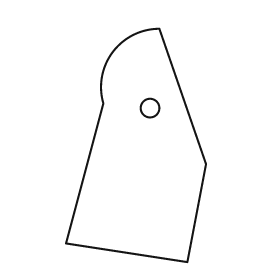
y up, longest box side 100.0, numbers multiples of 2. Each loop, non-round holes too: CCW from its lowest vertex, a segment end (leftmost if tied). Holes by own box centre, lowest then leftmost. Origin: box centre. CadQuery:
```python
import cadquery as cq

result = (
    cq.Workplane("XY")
    .moveTo(22.0, -50.0)
    .lineTo(30.0, -8.0)
    .lineTo(10.0, 50.0)
    .threePointArc((-10.0, 40.0), (-14.0, 18.0))
    .lineTo(-30.0, -42.0)
    .close()
    .moveTo(6.0, 16.0)
    .circle(4.0)
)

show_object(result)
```